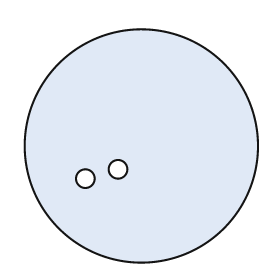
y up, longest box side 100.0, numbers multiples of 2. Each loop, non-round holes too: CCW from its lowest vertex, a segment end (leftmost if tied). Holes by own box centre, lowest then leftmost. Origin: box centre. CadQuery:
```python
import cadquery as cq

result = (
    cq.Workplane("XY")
    .moveTo(0.0, 0.0)
    .circle(50.0)
    .moveTo(-24.0, -14.0)
    .circle(4.0)
    .moveTo(-10.0, -10.0)
    .circle(4.0)
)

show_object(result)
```